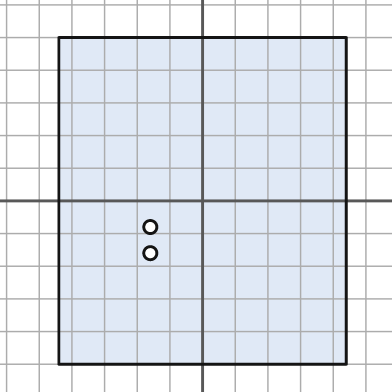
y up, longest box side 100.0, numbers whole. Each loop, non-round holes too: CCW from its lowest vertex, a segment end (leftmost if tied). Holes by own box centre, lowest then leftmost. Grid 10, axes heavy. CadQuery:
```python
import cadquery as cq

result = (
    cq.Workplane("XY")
    .moveTo(-44.0, -50.0)
    .lineTo(44.0, -50.0)
    .lineTo(44.0, 50.0)
    .lineTo(-44.0, 50.0)
    .close()
    .moveTo(-16.0, -16.0)
    .circle(2.0)
    .moveTo(-16.0, -8.0)
    .circle(2.0)
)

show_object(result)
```